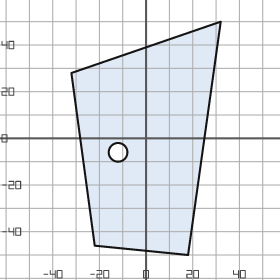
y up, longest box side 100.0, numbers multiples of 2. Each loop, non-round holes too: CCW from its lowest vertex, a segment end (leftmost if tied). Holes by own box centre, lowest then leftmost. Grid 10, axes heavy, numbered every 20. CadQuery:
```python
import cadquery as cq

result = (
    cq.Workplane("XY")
    .moveTo(18.0, -50.0)
    .lineTo(32.0, 50.0)
    .lineTo(-32.0, 28.0)
    .lineTo(-22.0, -46.0)
    .close()
    .moveTo(-12.0, -6.0)
    .circle(4.0)
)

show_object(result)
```